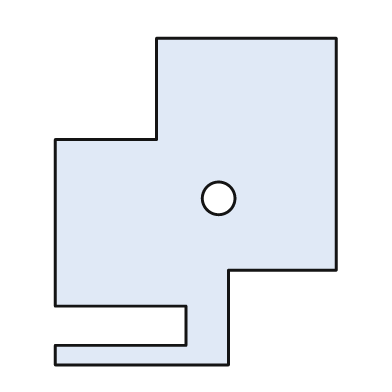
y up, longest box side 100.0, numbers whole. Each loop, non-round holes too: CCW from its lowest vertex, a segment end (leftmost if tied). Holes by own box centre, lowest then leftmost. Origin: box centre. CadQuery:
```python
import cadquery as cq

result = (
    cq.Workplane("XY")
    .moveTo(-43.0, -50.0)
    .lineTo(10.0, -50.0)
    .lineTo(10.0, -21.0)
    .lineTo(43.0, -21.0)
    .lineTo(43.0, 50.0)
    .lineTo(-12.0, 50.0)
    .lineTo(-12.0, 19.0)
    .lineTo(-43.0, 19.0)
    .lineTo(-43.0, -32.0)
    .lineTo(-3.0, -32.0)
    .lineTo(-3.0, -44.0)
    .lineTo(-43.0, -44.0)
    .close()
    .moveTo(7.0, 1.0)
    .circle(5.0)
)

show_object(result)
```